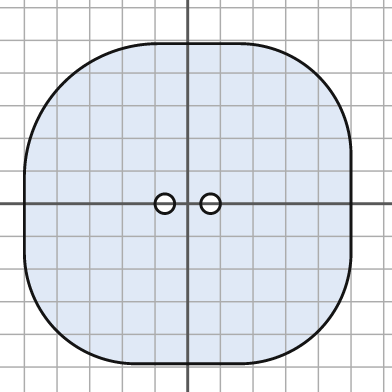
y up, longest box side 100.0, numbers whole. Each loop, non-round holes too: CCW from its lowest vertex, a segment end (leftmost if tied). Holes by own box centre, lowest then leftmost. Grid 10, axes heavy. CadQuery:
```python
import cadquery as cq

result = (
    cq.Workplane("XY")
    .moveTo(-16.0, -49.0)
    .lineTo(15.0, -49.0)
    .threePointArc((40.0, -39.0), (50.0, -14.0))
    .lineTo(50.0, 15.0)
    .threePointArc((40.0, 39.0), (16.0, 49.0))
    .lineTo(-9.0, 49.0)
    .threePointArc((-38.0, 37.0), (-50.0, 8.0))
    .lineTo(-50.0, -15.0)
    .threePointArc((-40.0, -39.0), (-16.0, -49.0))
    .close()
    .moveTo(-7.0, 0.0)
    .circle(3.0)
    .moveTo(7.0, 0.0)
    .circle(3.0)
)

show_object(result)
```